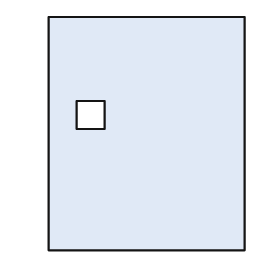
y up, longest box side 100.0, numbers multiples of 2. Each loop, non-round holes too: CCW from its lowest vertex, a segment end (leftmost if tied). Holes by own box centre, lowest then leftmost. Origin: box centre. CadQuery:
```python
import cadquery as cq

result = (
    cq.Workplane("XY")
    .moveTo(-42.0, -50.0)
    .lineTo(42.0, -50.0)
    .lineTo(42.0, 50.0)
    .lineTo(-42.0, 50.0)
    .close()
    .moveTo(-30.0, 2.0)
    .lineTo(-18.0, 2.0)
    .lineTo(-18.0, 14.0)
    .lineTo(-30.0, 14.0)
    .close()
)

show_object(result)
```